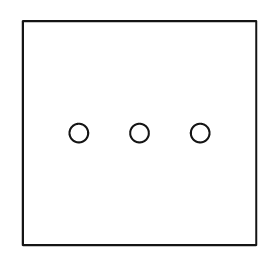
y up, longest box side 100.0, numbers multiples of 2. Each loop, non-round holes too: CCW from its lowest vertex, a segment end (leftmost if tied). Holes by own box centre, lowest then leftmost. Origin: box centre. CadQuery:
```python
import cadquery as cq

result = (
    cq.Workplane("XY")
    .moveTo(-50.0, -48.0)
    .lineTo(50.0, -48.0)
    .lineTo(50.0, 48.0)
    .lineTo(-50.0, 48.0)
    .close()
    .moveTo(-26.0, 0.0)
    .circle(4.0)
    .moveTo(0.0, 0.0)
    .circle(4.0)
    .moveTo(26.0, 0.0)
    .circle(4.0)
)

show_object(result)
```